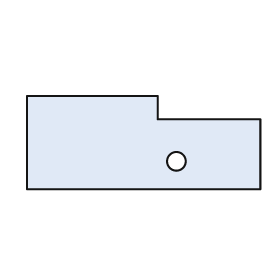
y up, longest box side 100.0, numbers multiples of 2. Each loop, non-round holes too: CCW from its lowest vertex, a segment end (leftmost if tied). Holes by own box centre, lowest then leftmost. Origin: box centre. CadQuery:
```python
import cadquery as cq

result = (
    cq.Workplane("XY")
    .moveTo(-50.0, -20.0)
    .lineTo(50.0, -20.0)
    .lineTo(50.0, 10.0)
    .lineTo(6.0, 10.0)
    .lineTo(6.0, 20.0)
    .lineTo(-50.0, 20.0)
    .close()
    .moveTo(14.0, -8.0)
    .circle(4.0)
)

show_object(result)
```